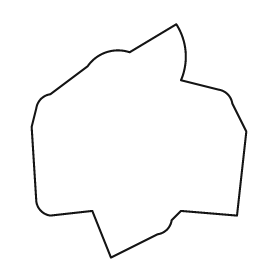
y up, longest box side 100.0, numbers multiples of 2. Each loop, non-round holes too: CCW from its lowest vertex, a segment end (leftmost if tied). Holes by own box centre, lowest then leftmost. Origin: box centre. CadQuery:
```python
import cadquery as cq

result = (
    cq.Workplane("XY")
    .moveTo(-12.0, -50.0)
    .lineTo(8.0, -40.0)
    .threePointArc((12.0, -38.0), (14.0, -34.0))
    .lineTo(18.0, -30.0)
    .lineTo(42.0, -32.0)
    .lineTo(46.0, 4.0)
    .lineTo(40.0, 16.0)
    .threePointArc((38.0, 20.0), (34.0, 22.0))
    .lineTo(18.0, 26.0)
    .threePointArc((20.0, 38.0), (16.0, 50.0))
    .lineTo(-4.0, 38.0)
    .threePointArc((-14.0, 38.0), (-22.0, 32.0))
    .lineTo(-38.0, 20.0)
    .threePointArc((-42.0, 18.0), (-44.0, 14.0))
    .lineTo(-46.0, 6.0)
    .lineTo(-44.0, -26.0)
    .threePointArc((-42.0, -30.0), (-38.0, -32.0))
    .lineTo(-20.0, -30.0)
    .close()
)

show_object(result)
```